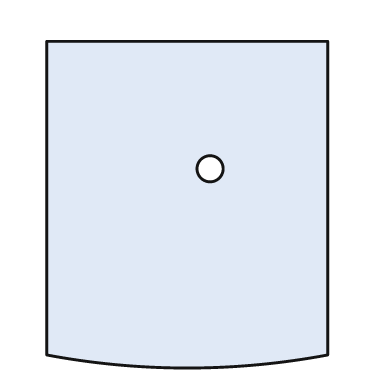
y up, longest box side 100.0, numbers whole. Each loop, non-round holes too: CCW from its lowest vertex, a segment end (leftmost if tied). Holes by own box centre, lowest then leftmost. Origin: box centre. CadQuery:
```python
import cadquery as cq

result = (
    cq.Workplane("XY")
    .moveTo(-43.0, -46.0)
    .threePointArc((0.0, -50.0), (43.0, -46.0))
    .lineTo(43.0, 50.0)
    .lineTo(-43.0, 50.0)
    .close()
    .moveTo(7.0, 11.0)
    .circle(4.0)
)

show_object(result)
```